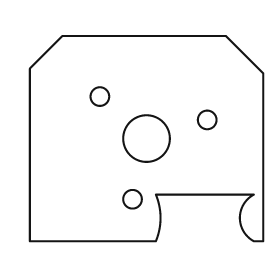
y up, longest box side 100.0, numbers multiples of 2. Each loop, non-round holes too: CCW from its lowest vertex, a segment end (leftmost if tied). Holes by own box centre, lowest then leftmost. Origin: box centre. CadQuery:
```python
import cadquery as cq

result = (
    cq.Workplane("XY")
    .moveTo(-50.0, -44.0)
    .lineTo(4.0, -44.0)
    .threePointArc((6.0, -34.0), (4.0, -24.0))
    .lineTo(46.0, -24.0)
    .threePointArc((40.0, -34.0), (46.0, -44.0))
    .lineTo(50.0, -44.0)
    .lineTo(50.0, 28.0)
    .lineTo(34.0, 44.0)
    .lineTo(-36.0, 44.0)
    .lineTo(-50.0, 30.0)
    .close()
    .moveTo(-6.0, -26.0)
    .circle(4.0)
    .moveTo(0.0, 0.0)
    .circle(10.0)
    .moveTo(26.0, 8.0)
    .circle(4.0)
    .moveTo(-20.0, 18.0)
    .circle(4.0)
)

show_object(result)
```